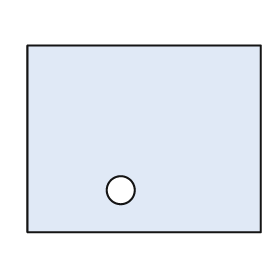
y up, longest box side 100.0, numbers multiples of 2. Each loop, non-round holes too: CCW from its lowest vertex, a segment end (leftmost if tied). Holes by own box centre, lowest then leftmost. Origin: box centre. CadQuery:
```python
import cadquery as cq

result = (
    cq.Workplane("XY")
    .moveTo(-50.0, -40.0)
    .lineTo(50.0, -40.0)
    .lineTo(50.0, 40.0)
    .lineTo(-50.0, 40.0)
    .close()
    .moveTo(-10.0, -22.0)
    .circle(6.0)
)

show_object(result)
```